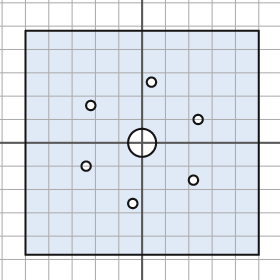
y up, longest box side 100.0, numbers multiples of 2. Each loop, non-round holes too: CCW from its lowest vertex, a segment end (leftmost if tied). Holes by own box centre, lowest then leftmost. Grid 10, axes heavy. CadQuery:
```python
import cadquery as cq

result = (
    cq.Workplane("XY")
    .moveTo(-50.0, -48.0)
    .lineTo(50.0, -48.0)
    .lineTo(50.0, 48.0)
    .lineTo(-50.0, 48.0)
    .close()
    .moveTo(-4.0, -26.0)
    .circle(2.0)
    .moveTo(22.0, -16.0)
    .circle(2.0)
    .moveTo(-24.0, -10.0)
    .circle(2.0)
    .moveTo(0.0, 0.0)
    .circle(6.0)
    .moveTo(24.0, 10.0)
    .circle(2.0)
    .moveTo(-22.0, 16.0)
    .circle(2.0)
    .moveTo(4.0, 26.0)
    .circle(2.0)
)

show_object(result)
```